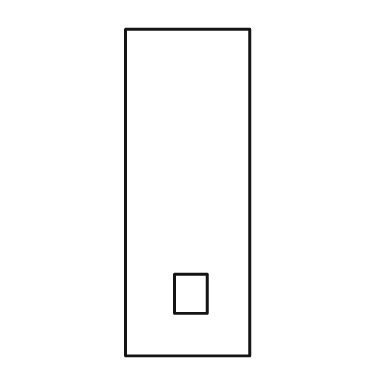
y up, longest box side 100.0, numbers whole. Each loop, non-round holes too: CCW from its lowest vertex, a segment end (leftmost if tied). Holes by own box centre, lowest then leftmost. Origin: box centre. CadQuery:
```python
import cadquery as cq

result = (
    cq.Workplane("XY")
    .moveTo(-19.0, -50.0)
    .lineTo(19.0, -50.0)
    .lineTo(19.0, 50.0)
    .lineTo(-19.0, 50.0)
    .close()
    .moveTo(-4.0, -37.0)
    .lineTo(6.0, -37.0)
    .lineTo(6.0, -25.0)
    .lineTo(-4.0, -25.0)
    .close()
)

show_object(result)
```